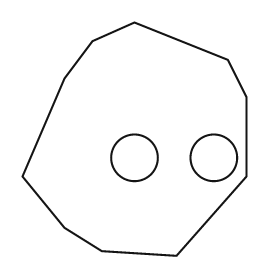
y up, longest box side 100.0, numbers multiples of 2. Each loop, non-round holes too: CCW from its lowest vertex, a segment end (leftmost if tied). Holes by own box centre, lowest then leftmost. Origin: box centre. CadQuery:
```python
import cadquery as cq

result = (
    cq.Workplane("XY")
    .moveTo(18.0, -50.0)
    .lineTo(48.0, -16.0)
    .lineTo(48.0, 18.0)
    .lineTo(40.0, 34.0)
    .lineTo(0.0, 50.0)
    .lineTo(-18.0, 42.0)
    .lineTo(-30.0, 26.0)
    .lineTo(-48.0, -16.0)
    .lineTo(-30.0, -38.0)
    .lineTo(-14.0, -48.0)
    .close()
    .moveTo(0.0, -8.0)
    .circle(10.0)
    .moveTo(34.0, -8.0)
    .circle(10.0)
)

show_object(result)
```